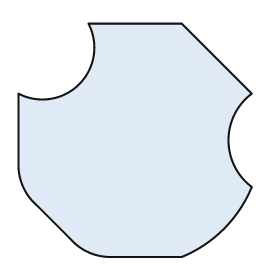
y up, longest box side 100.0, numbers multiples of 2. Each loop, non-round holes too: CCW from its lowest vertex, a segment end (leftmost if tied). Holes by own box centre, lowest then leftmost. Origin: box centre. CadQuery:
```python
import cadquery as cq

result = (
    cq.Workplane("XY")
    .moveTo(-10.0, -50.0)
    .lineTo(20.0, -50.0)
    .threePointArc((38.0, -38.0), (50.0, -20.0))
    .threePointArc((40.0, 0.0), (50.0, 20.0))
    .lineTo(20.0, 50.0)
    .lineTo(-20.0, 50.0)
    .threePointArc((-24.0, 24.0), (-50.0, 20.0))
    .lineTo(-50.0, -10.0)
    .threePointArc((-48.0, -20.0), (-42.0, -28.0))
    .lineTo(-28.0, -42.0)
    .threePointArc((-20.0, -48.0), (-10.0, -50.0))
    .close()
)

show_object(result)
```